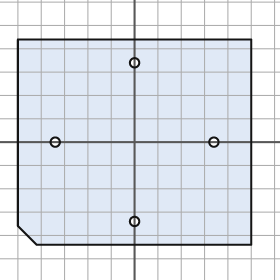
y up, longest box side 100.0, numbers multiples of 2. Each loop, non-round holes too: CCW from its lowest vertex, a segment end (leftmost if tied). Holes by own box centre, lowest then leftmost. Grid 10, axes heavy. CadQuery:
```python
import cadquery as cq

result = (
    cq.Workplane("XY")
    .moveTo(-42.0, -44.0)
    .lineTo(50.0, -44.0)
    .lineTo(50.0, 44.0)
    .lineTo(-50.0, 44.0)
    .lineTo(-50.0, -36.0)
    .close()
    .moveTo(0.0, -34.0)
    .circle(2.0)
    .moveTo(-34.0, 0.0)
    .circle(2.0)
    .moveTo(34.0, 0.0)
    .circle(2.0)
    .moveTo(0.0, 34.0)
    .circle(2.0)
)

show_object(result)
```